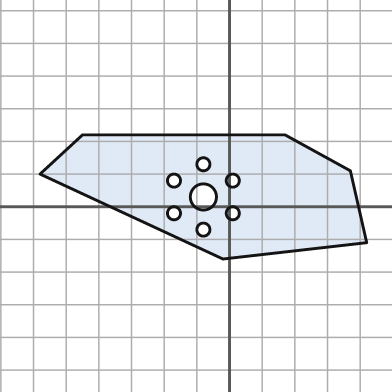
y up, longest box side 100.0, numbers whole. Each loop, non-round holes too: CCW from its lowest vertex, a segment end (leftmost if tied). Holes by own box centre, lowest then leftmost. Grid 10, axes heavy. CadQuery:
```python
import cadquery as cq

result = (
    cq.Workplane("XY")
    .moveTo(-2.0, -16.0)
    .lineTo(42.0, -11.0)
    .lineTo(37.0, 11.0)
    .lineTo(17.0, 22.0)
    .lineTo(-45.0, 22.0)
    .lineTo(-58.0, 10.0)
    .close()
    .moveTo(-8.0, -7.0)
    .circle(2.0)
    .moveTo(-17.0, -2.0)
    .circle(2.0)
    .moveTo(1.0, -2.0)
    .circle(2.0)
    .moveTo(-8.0, 3.0)
    .circle(4.0)
    .moveTo(-17.0, 8.0)
    .circle(2.0)
    .moveTo(1.0, 8.0)
    .circle(2.0)
    .moveTo(-8.0, 13.0)
    .circle(2.0)
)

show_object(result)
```